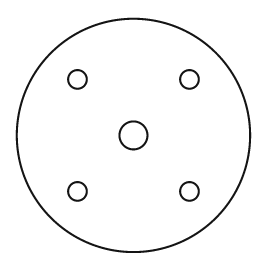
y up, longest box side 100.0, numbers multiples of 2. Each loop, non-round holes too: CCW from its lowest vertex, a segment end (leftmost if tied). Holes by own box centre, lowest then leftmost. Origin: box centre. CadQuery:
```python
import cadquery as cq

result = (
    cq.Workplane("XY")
    .moveTo(0.0, 0.0)
    .circle(50.0)
    .moveTo(-24.0, -24.0)
    .circle(4.0)
    .moveTo(24.0, -24.0)
    .circle(4.0)
    .moveTo(0.0, 0.0)
    .circle(6.0)
    .moveTo(-24.0, 24.0)
    .circle(4.0)
    .moveTo(24.0, 24.0)
    .circle(4.0)
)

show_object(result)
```